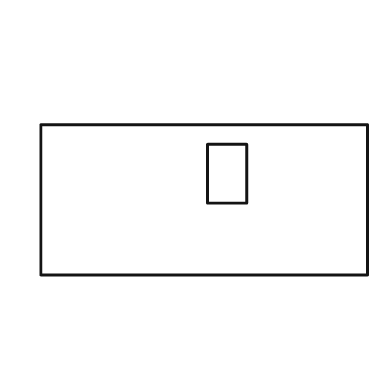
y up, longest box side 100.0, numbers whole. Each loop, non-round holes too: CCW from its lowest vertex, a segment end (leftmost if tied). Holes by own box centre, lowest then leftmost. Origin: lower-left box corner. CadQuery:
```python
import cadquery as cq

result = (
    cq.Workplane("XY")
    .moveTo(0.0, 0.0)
    .lineTo(100.0, 0.0)
    .lineTo(100.0, 46.0)
    .lineTo(0.0, 46.0)
    .close()
    .moveTo(51.0, 22.0)
    .lineTo(63.0, 22.0)
    .lineTo(63.0, 40.0)
    .lineTo(51.0, 40.0)
    .close()
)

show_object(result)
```